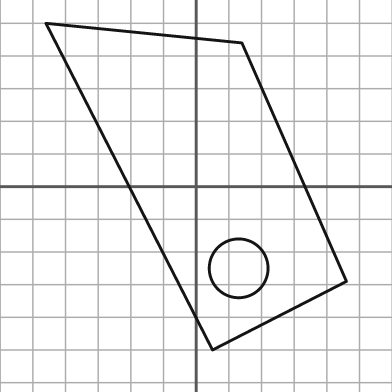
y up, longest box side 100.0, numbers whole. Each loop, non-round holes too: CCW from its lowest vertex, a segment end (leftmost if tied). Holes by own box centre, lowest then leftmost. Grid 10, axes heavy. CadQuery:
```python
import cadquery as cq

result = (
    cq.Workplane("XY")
    .moveTo(5.0, -50.0)
    .lineTo(46.0, -29.0)
    .lineTo(14.0, 44.0)
    .lineTo(-46.0, 50.0)
    .close()
    .moveTo(13.0, -25.0)
    .circle(9.0)
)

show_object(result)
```